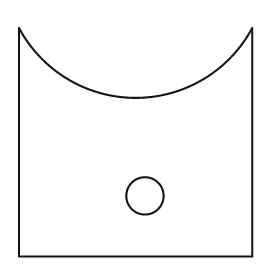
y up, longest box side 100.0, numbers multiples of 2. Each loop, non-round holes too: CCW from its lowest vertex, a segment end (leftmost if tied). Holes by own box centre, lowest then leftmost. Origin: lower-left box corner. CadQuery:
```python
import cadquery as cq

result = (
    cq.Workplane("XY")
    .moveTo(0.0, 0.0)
    .lineTo(100.0, 0.0)
    .lineTo(100.0, 98.0)
    .threePointArc((50.0, 68.0), (0.0, 98.0))
    .close()
    .moveTo(54.0, 26.0)
    .circle(8.0)
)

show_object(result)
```